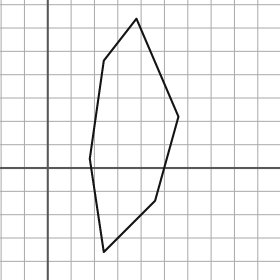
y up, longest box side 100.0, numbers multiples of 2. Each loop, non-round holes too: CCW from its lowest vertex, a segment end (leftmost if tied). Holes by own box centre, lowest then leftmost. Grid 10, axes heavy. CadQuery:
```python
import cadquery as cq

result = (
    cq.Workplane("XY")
    .moveTo(24.0, -36.0)
    .lineTo(46.0, -14.0)
    .lineTo(56.0, 22.0)
    .lineTo(38.0, 64.0)
    .lineTo(24.0, 46.0)
    .lineTo(18.0, 4.0)
    .close()
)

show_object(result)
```